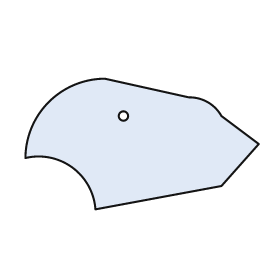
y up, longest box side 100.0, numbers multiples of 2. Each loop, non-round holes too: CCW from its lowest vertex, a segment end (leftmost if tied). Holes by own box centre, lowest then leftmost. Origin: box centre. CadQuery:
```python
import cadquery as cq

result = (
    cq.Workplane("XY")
    .moveTo(-20.0, -28.0)
    .lineTo(34.0, -18.0)
    .lineTo(50.0, 0.0)
    .lineTo(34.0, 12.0)
    .threePointArc((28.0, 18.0), (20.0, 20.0))
    .lineTo(-16.0, 28.0)
    .threePointArc((-40.0, 18.0), (-50.0, -6.0))
    .threePointArc((-30.0, -10.0), (-20.0, -28.0))
    .close()
    .moveTo(-8.0, 12.0)
    .circle(2.0)
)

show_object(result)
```